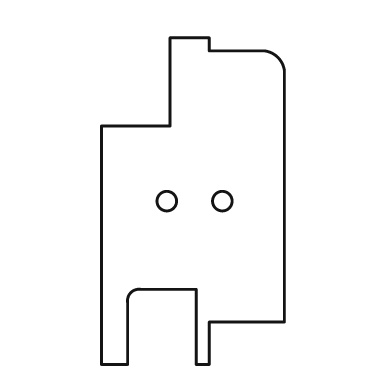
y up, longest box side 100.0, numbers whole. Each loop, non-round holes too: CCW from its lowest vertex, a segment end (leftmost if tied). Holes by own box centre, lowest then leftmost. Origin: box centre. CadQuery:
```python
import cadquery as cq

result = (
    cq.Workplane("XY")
    .moveTo(-28.0, -50.0)
    .lineTo(-20.0, -50.0)
    .lineTo(-20.0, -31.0)
    .threePointArc((-19.0, -28.0), (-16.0, -27.0))
    .lineTo(1.0, -27.0)
    .lineTo(1.0, -50.0)
    .lineTo(5.0, -50.0)
    .lineTo(5.0, -37.0)
    .lineTo(28.0, -37.0)
    .lineTo(28.0, 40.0)
    .threePointArc((26.0, 44.0), (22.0, 46.0))
    .lineTo(5.0, 46.0)
    .lineTo(5.0, 50.0)
    .lineTo(-7.0, 50.0)
    .lineTo(-7.0, 23.0)
    .lineTo(-28.0, 23.0)
    .close()
    .moveTo(-8.0, 0.0)
    .circle(3.0)
    .moveTo(9.0, 0.0)
    .circle(3.0)
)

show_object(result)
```